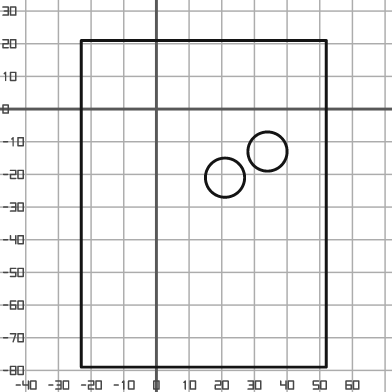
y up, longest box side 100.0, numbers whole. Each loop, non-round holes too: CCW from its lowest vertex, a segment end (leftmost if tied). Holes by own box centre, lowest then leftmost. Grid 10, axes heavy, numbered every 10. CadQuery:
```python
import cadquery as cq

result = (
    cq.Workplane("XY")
    .moveTo(-23.0, -79.0)
    .lineTo(52.0, -79.0)
    .lineTo(52.0, 21.0)
    .lineTo(-23.0, 21.0)
    .close()
    .moveTo(21.0, -21.0)
    .circle(6.0)
    .moveTo(34.0, -13.0)
    .circle(6.0)
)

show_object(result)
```